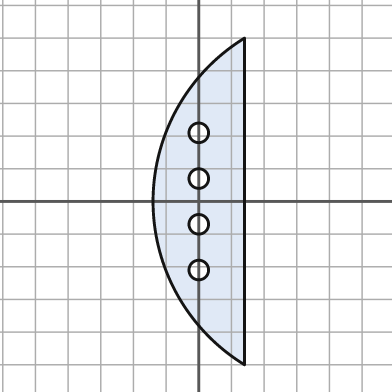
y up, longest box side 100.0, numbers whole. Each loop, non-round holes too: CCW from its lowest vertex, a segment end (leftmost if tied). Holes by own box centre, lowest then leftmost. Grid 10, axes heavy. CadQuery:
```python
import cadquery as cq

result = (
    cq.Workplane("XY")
    .moveTo(14.0, -50.0)
    .lineTo(14.0, 50.0)
    .threePointArc((-14.0, 0.0), (14.0, -50.0))
    .close()
    .moveTo(0.0, -21.0)
    .circle(3.0)
    .moveTo(0.0, -7.0)
    .circle(3.0)
    .moveTo(0.0, 7.0)
    .circle(3.0)
    .moveTo(0.0, 21.0)
    .circle(3.0)
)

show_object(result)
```